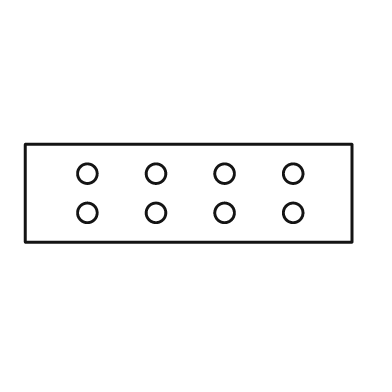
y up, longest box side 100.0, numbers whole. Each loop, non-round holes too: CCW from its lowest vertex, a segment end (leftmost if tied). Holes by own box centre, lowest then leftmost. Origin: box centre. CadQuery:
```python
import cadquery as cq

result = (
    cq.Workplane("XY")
    .moveTo(-50.0, -15.0)
    .lineTo(50.0, -15.0)
    .lineTo(50.0, 15.0)
    .lineTo(-50.0, 15.0)
    .close()
    .moveTo(-31.0, -6.0)
    .circle(3.0)
    .moveTo(-10.0, -6.0)
    .circle(3.0)
    .moveTo(11.0, -6.0)
    .circle(3.0)
    .moveTo(32.0, -6.0)
    .circle(3.0)
    .moveTo(-31.0, 6.0)
    .circle(3.0)
    .moveTo(-10.0, 6.0)
    .circle(3.0)
    .moveTo(11.0, 6.0)
    .circle(3.0)
    .moveTo(32.0, 6.0)
    .circle(3.0)
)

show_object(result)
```